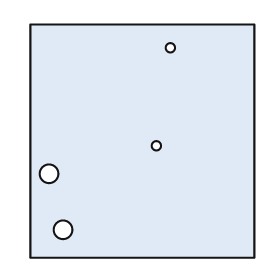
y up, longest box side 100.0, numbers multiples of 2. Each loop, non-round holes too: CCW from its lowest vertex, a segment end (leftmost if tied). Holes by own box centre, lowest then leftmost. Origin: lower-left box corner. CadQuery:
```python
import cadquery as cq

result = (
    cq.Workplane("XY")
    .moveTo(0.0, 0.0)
    .lineTo(96.0, 0.0)
    .lineTo(96.0, 100.0)
    .lineTo(0.0, 100.0)
    .close()
    .moveTo(14.0, 12.0)
    .circle(4.0)
    .moveTo(8.0, 36.0)
    .circle(4.0)
    .moveTo(54.0, 48.0)
    .circle(2.0)
    .moveTo(60.0, 90.0)
    .circle(2.0)
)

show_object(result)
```